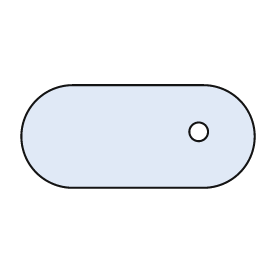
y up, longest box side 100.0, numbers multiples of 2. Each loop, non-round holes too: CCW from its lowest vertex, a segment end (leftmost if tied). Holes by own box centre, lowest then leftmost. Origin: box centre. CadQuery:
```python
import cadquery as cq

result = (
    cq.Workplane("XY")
    .moveTo(-28.0, -22.0)
    .lineTo(28.0, -22.0)
    .threePointArc((50.0, 0.0), (28.0, 22.0))
    .lineTo(-28.0, 22.0)
    .threePointArc((-50.0, 0.0), (-28.0, -22.0))
    .close()
    .moveTo(26.0, 2.0)
    .circle(4.0)
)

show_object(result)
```